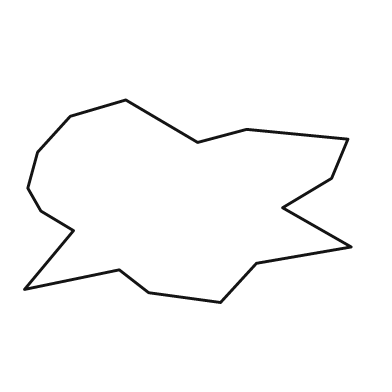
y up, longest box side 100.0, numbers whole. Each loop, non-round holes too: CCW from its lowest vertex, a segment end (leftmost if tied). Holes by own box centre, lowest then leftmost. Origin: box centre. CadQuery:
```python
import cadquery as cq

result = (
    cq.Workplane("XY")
    .moveTo(10.0, -31.0)
    .lineTo(21.0, -19.0)
    .lineTo(50.0, -14.0)
    .lineTo(29.0, -2.0)
    .lineTo(44.0, 7.0)
    .lineTo(49.0, 19.0)
    .lineTo(18.0, 22.0)
    .lineTo(3.0, 18.0)
    .lineTo(-19.0, 31.0)
    .lineTo(-36.0, 26.0)
    .lineTo(-46.0, 15.0)
    .lineTo(-49.0, 4.0)
    .lineTo(-45.0, -3.0)
    .lineTo(-35.0, -9.0)
    .lineTo(-50.0, -27.0)
    .lineTo(-21.0, -21.0)
    .lineTo(-12.0, -28.0)
    .close()
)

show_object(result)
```